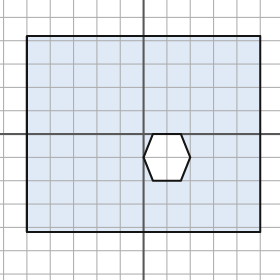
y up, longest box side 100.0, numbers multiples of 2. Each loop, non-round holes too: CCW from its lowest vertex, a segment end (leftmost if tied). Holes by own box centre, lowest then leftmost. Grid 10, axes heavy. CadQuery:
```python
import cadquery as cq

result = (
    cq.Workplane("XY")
    .moveTo(-50.0, -42.0)
    .lineTo(50.0, -42.0)
    .lineTo(50.0, 42.0)
    .lineTo(-50.0, 42.0)
    .close()
    .moveTo(4.0, -20.0)
    .lineTo(16.0, -20.0)
    .lineTo(20.0, -10.0)
    .lineTo(16.0, 0.0)
    .lineTo(4.0, 0.0)
    .lineTo(0.0, -10.0)
    .close()
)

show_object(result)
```